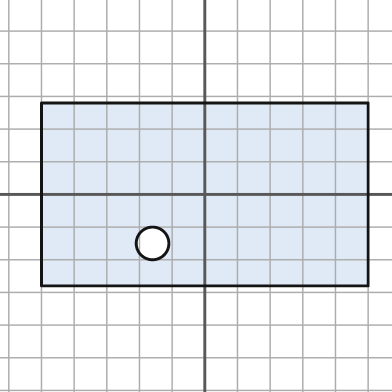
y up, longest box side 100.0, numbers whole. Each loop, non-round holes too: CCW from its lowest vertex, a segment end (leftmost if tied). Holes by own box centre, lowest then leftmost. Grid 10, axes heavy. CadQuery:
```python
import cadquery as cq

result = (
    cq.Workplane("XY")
    .moveTo(-50.0, -28.0)
    .lineTo(50.0, -28.0)
    .lineTo(50.0, 28.0)
    .lineTo(-50.0, 28.0)
    .close()
    .moveTo(-16.0, -15.0)
    .circle(5.0)
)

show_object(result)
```